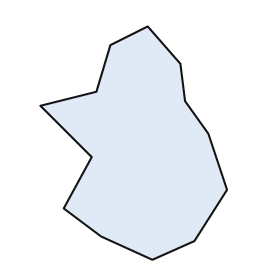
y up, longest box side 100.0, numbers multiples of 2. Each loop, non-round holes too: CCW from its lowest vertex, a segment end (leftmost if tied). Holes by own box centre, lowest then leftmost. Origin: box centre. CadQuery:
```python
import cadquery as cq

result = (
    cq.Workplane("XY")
    .moveTo(8.0, -50.0)
    .lineTo(26.0, -42.0)
    .lineTo(40.0, -20.0)
    .lineTo(32.0, 4.0)
    .lineTo(22.0, 18.0)
    .lineTo(20.0, 34.0)
    .lineTo(6.0, 50.0)
    .lineTo(-10.0, 42.0)
    .lineTo(-16.0, 22.0)
    .lineTo(-40.0, 16.0)
    .lineTo(-18.0, -6.0)
    .lineTo(-30.0, -28.0)
    .lineTo(-14.0, -40.0)
    .close()
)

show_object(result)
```